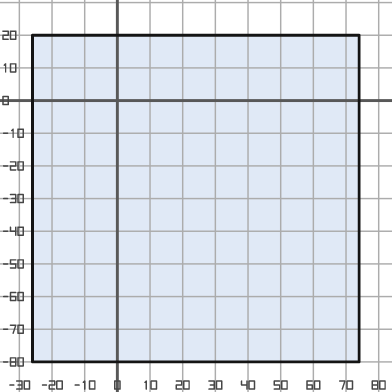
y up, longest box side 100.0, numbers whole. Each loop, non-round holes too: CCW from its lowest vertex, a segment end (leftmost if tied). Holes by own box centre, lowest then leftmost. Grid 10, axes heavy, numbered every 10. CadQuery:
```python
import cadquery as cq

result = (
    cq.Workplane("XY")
    .moveTo(-26.0, -80.0)
    .lineTo(74.0, -80.0)
    .lineTo(74.0, 20.0)
    .lineTo(-26.0, 20.0)
    .close()
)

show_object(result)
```